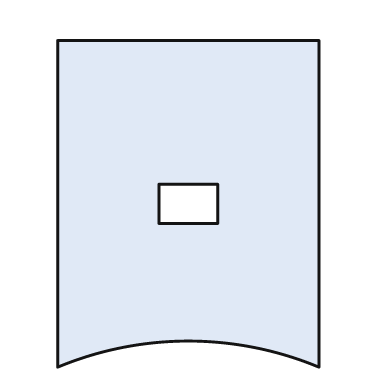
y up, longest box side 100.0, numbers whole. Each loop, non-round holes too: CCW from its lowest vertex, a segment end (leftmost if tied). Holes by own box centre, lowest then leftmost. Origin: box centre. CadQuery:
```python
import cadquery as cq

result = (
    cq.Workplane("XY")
    .moveTo(-40.0, -50.0)
    .threePointArc((0.0, -42.0), (40.0, -50.0))
    .lineTo(40.0, 50.0)
    .lineTo(-40.0, 50.0)
    .close()
    .moveTo(-9.0, -6.0)
    .lineTo(9.0, -6.0)
    .lineTo(9.0, 6.0)
    .lineTo(-9.0, 6.0)
    .close()
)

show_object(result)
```